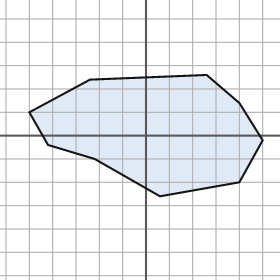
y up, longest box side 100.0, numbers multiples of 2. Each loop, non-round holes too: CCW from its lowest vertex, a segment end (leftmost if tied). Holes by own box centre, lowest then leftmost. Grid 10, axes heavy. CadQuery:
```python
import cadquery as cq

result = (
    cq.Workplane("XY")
    .moveTo(6.0, -26.0)
    .lineTo(40.0, -20.0)
    .lineTo(50.0, -2.0)
    .lineTo(40.0, 14.0)
    .lineTo(26.0, 26.0)
    .lineTo(-24.0, 24.0)
    .lineTo(-50.0, 10.0)
    .lineTo(-42.0, -4.0)
    .lineTo(-22.0, -10.0)
    .close()
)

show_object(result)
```